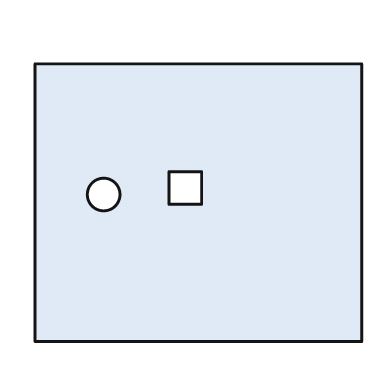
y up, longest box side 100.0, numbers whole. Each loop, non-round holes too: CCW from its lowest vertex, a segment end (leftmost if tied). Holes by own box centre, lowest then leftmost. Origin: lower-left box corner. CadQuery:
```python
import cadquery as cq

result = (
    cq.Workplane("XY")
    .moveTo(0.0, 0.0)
    .lineTo(100.0, 0.0)
    .lineTo(100.0, 85.0)
    .lineTo(0.0, 85.0)
    .close()
    .moveTo(21.0, 45.0)
    .circle(5.0)
    .moveTo(41.0, 42.0)
    .lineTo(51.0, 42.0)
    .lineTo(51.0, 52.0)
    .lineTo(41.0, 52.0)
    .close()
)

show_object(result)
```